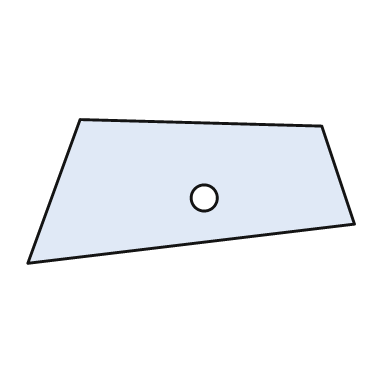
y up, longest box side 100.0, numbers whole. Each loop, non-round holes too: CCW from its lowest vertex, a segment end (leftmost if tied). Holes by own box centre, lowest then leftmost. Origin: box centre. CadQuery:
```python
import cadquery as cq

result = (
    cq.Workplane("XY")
    .moveTo(-50.0, -22.0)
    .lineTo(50.0, -10.0)
    .lineTo(40.0, 20.0)
    .lineTo(-34.0, 22.0)
    .close()
    .moveTo(4.0, -2.0)
    .circle(4.0)
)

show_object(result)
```